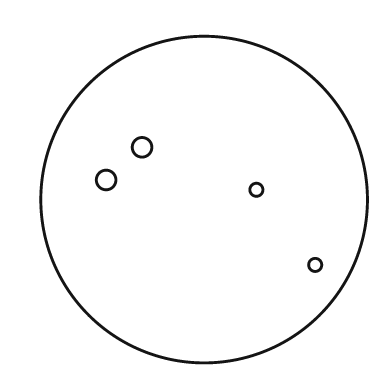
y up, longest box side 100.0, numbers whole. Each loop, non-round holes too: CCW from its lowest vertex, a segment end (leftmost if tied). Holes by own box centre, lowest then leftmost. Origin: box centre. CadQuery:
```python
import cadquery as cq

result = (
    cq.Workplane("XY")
    .moveTo(0.0, 0.0)
    .circle(50.0)
    .moveTo(34.0, -20.0)
    .circle(2.0)
    .moveTo(16.0, 3.0)
    .circle(2.0)
    .moveTo(-30.0, 6.0)
    .circle(3.0)
    .moveTo(-19.0, 16.0)
    .circle(3.0)
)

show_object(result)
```